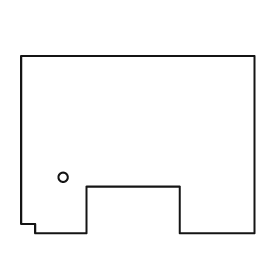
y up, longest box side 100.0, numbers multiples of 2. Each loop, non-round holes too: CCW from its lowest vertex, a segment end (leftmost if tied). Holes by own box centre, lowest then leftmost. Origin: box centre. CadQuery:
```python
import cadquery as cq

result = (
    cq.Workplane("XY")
    .moveTo(-44.0, -38.0)
    .lineTo(-22.0, -38.0)
    .lineTo(-22.0, -18.0)
    .lineTo(18.0, -18.0)
    .lineTo(18.0, -38.0)
    .lineTo(50.0, -38.0)
    .lineTo(50.0, 38.0)
    .lineTo(-50.0, 38.0)
    .lineTo(-50.0, -34.0)
    .lineTo(-44.0, -34.0)
    .close()
    .moveTo(-32.0, -14.0)
    .circle(2.0)
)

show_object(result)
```